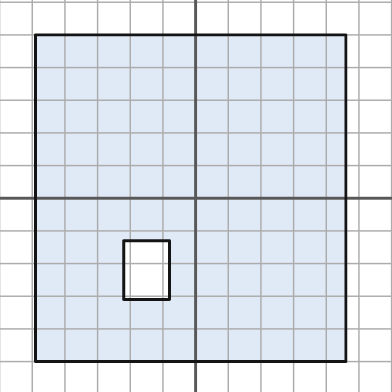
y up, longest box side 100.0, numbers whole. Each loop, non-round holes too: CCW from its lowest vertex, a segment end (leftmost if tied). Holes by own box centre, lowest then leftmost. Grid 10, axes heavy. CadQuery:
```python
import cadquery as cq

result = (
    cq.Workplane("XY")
    .moveTo(-49.0, -50.0)
    .lineTo(46.0, -50.0)
    .lineTo(46.0, 50.0)
    .lineTo(-49.0, 50.0)
    .close()
    .moveTo(-22.0, -31.0)
    .lineTo(-8.0, -31.0)
    .lineTo(-8.0, -13.0)
    .lineTo(-22.0, -13.0)
    .close()
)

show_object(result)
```